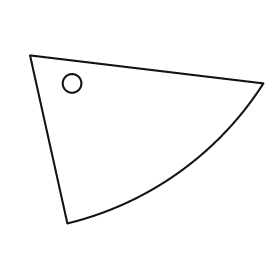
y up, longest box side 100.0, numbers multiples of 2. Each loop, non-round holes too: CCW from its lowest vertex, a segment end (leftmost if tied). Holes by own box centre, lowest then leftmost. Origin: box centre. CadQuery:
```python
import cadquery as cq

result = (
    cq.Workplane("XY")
    .moveTo(-34.0, -36.0)
    .threePointArc((14.0, -14.0), (50.0, 24.0))
    .lineTo(-50.0, 36.0)
    .close()
    .moveTo(-32.0, 24.0)
    .circle(4.0)
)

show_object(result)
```